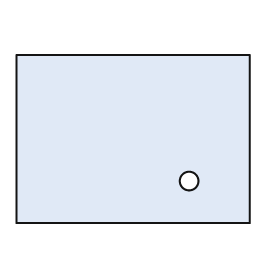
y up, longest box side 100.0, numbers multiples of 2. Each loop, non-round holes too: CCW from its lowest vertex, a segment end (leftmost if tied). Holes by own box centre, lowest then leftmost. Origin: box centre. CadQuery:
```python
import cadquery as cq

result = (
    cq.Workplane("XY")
    .moveTo(-50.0, -36.0)
    .lineTo(50.0, -36.0)
    .lineTo(50.0, 36.0)
    .lineTo(-50.0, 36.0)
    .close()
    .moveTo(24.0, -18.0)
    .circle(4.0)
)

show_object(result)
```